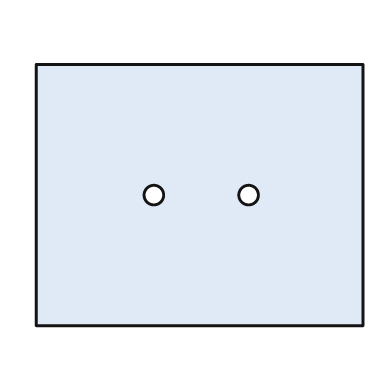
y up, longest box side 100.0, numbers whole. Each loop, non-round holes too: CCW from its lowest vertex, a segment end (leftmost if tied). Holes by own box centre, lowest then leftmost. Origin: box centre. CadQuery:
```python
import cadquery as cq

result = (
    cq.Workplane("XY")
    .moveTo(-50.0, -40.0)
    .lineTo(50.0, -40.0)
    .lineTo(50.0, 40.0)
    .lineTo(-50.0, 40.0)
    .close()
    .moveTo(-14.0, 0.0)
    .circle(3.0)
    .moveTo(15.0, 0.0)
    .circle(3.0)
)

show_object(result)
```